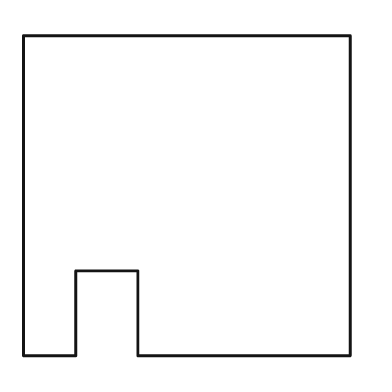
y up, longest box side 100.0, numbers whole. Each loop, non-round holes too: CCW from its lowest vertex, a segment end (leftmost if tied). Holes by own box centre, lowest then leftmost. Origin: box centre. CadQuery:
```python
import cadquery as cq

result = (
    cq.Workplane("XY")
    .moveTo(-50.0, -49.0)
    .lineTo(-34.0, -49.0)
    .lineTo(-34.0, -23.0)
    .lineTo(-15.0, -23.0)
    .lineTo(-15.0, -49.0)
    .lineTo(50.0, -49.0)
    .lineTo(50.0, 49.0)
    .lineTo(-50.0, 49.0)
    .close()
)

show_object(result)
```